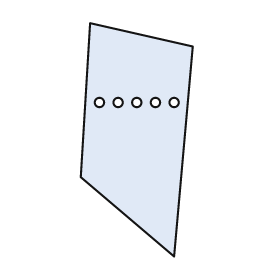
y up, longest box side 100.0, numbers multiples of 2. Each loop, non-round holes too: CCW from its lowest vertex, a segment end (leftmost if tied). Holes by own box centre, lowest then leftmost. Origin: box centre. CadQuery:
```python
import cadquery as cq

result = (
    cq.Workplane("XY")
    .moveTo(16.0, -50.0)
    .lineTo(24.0, 40.0)
    .lineTo(-20.0, 50.0)
    .lineTo(-24.0, -16.0)
    .close()
    .moveTo(-16.0, 16.0)
    .circle(2.0)
    .moveTo(-8.0, 16.0)
    .circle(2.0)
    .moveTo(0.0, 16.0)
    .circle(2.0)
    .moveTo(8.0, 16.0)
    .circle(2.0)
    .moveTo(16.0, 16.0)
    .circle(2.0)
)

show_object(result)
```